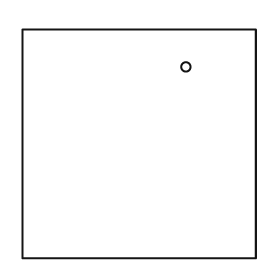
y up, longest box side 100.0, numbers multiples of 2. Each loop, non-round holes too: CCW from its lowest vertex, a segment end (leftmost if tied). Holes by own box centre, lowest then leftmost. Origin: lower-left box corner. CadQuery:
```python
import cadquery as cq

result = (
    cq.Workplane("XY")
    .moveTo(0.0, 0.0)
    .lineTo(100.0, 0.0)
    .lineTo(100.0, 98.0)
    .lineTo(0.0, 98.0)
    .close()
    .moveTo(70.0, 82.0)
    .circle(2.0)
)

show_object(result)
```